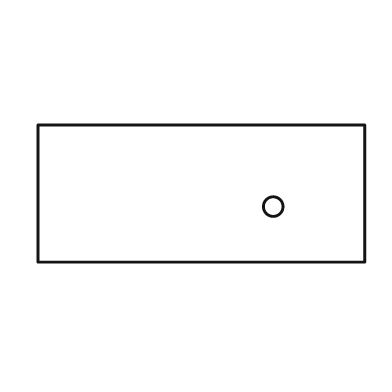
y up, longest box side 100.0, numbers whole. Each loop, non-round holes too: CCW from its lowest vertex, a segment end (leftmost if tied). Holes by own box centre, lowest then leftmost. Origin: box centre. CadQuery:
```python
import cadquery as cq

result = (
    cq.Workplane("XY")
    .moveTo(-50.0, -21.0)
    .lineTo(50.0, -21.0)
    .lineTo(50.0, 21.0)
    .lineTo(-50.0, 21.0)
    .close()
    .moveTo(22.0, -4.0)
    .circle(3.0)
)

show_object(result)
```